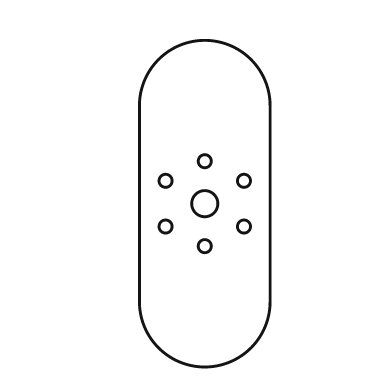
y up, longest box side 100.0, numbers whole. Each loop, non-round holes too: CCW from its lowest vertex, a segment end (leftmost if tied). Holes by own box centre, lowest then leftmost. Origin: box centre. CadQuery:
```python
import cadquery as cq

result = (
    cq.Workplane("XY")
    .moveTo(-20.0, -30.0)
    .threePointArc((0.0, -50.0), (20.0, -30.0))
    .lineTo(20.0, 30.0)
    .threePointArc((0.0, 50.0), (-20.0, 30.0))
    .close()
    .moveTo(0.0, -13.0)
    .circle(2.0)
    .moveTo(-12.0, -7.0)
    .circle(2.0)
    .moveTo(12.0, -7.0)
    .circle(2.0)
    .moveTo(0.0, 0.0)
    .circle(4.0)
    .moveTo(-12.0, 7.0)
    .circle(2.0)
    .moveTo(12.0, 7.0)
    .circle(2.0)
    .moveTo(0.0, 13.0)
    .circle(2.0)
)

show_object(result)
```